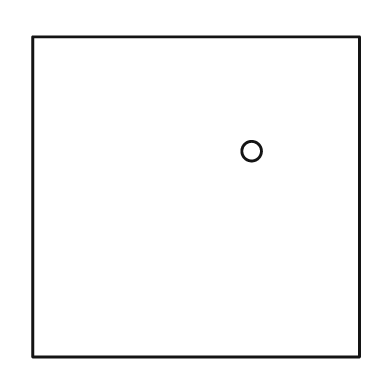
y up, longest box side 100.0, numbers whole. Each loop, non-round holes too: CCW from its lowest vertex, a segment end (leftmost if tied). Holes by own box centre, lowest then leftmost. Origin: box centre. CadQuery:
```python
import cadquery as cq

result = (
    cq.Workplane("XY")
    .moveTo(-50.0, -49.0)
    .lineTo(50.0, -49.0)
    .lineTo(50.0, 49.0)
    .lineTo(-50.0, 49.0)
    .close()
    .moveTo(17.0, 14.0)
    .circle(3.0)
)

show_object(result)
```